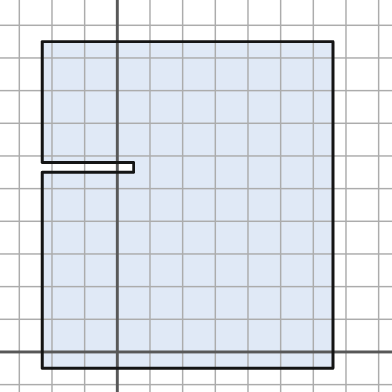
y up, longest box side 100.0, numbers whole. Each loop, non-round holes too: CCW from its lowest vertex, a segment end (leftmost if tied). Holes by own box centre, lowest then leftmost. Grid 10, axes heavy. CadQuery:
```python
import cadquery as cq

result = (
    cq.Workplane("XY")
    .moveTo(-23.0, -5.0)
    .lineTo(66.0, -5.0)
    .lineTo(66.0, 95.0)
    .lineTo(-23.0, 95.0)
    .lineTo(-23.0, 58.0)
    .lineTo(5.0, 58.0)
    .lineTo(5.0, 55.0)
    .lineTo(-23.0, 55.0)
    .close()
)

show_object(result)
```